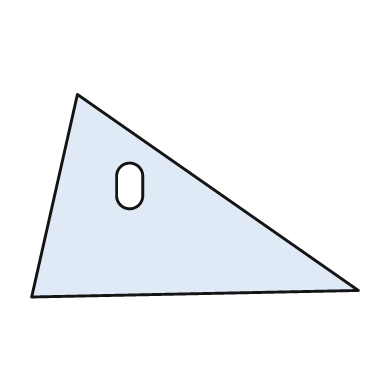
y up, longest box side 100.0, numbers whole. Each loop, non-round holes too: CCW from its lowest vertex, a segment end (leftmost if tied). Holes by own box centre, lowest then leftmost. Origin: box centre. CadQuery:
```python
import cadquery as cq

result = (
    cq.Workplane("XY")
    .moveTo(-50.0, -31.0)
    .lineTo(50.0, -29.0)
    .lineTo(-36.0, 31.0)
    .close()
    .moveTo(-24.0, 0.0)
    .threePointArc((-20.0, -4.0), (-16.0, 0.0))
    .lineTo(-16.0, 6.0)
    .threePointArc((-20.0, 10.0), (-24.0, 6.0))
    .close()
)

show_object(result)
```